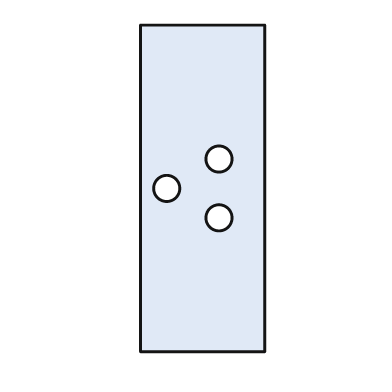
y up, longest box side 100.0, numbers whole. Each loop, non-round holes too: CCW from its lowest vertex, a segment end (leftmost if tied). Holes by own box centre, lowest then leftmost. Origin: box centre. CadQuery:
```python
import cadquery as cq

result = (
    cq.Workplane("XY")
    .moveTo(-19.0, -50.0)
    .lineTo(19.0, -50.0)
    .lineTo(19.0, 50.0)
    .lineTo(-19.0, 50.0)
    .close()
    .moveTo(5.0, -9.0)
    .circle(4.0)
    .moveTo(-11.0, 0.0)
    .circle(4.0)
    .moveTo(5.0, 9.0)
    .circle(4.0)
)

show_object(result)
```